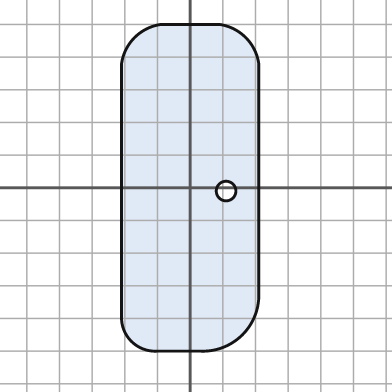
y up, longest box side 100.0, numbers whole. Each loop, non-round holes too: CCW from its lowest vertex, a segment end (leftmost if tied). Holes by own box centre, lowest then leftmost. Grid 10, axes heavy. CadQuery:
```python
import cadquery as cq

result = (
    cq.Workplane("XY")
    .moveTo(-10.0, -50.0)
    .lineTo(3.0, -50.0)
    .threePointArc((16.0, -45.0), (21.0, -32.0))
    .lineTo(21.0, 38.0)
    .threePointArc((17.0, 46.0), (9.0, 50.0))
    .lineTo(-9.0, 50.0)
    .threePointArc((-17.0, 46.0), (-21.0, 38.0))
    .lineTo(-21.0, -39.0)
    .threePointArc((-18.0, -47.0), (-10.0, -50.0))
    .close()
    .moveTo(11.0, -1.0)
    .circle(3.0)
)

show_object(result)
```